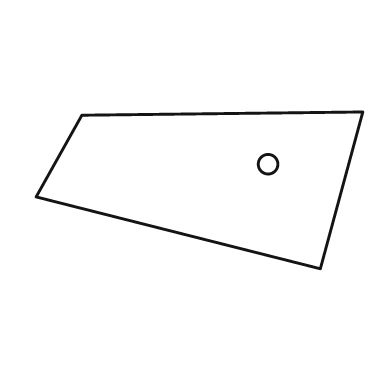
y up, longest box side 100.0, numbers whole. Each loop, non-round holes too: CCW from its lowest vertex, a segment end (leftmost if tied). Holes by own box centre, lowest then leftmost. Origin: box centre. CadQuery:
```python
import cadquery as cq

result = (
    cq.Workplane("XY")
    .moveTo(37.0, -24.0)
    .lineTo(50.0, 24.0)
    .lineTo(-36.0, 23.0)
    .lineTo(-50.0, -2.0)
    .close()
    .moveTo(21.0, 8.0)
    .circle(3.0)
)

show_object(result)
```